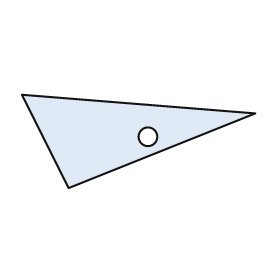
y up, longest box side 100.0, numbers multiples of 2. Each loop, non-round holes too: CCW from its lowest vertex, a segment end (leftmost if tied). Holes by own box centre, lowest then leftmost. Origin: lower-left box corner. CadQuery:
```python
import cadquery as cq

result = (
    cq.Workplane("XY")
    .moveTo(20.0, 0.0)
    .lineTo(100.0, 32.0)
    .lineTo(0.0, 40.0)
    .close()
    .moveTo(54.0, 22.0)
    .circle(4.0)
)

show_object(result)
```